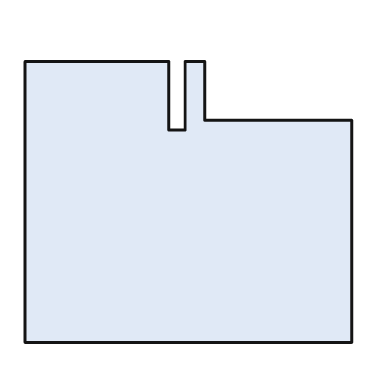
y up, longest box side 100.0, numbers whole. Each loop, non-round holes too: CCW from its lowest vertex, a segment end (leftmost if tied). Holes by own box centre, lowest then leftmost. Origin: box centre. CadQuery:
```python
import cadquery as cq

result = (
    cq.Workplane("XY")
    .moveTo(-50.0, -43.0)
    .lineTo(50.0, -43.0)
    .lineTo(50.0, 25.0)
    .lineTo(5.0, 25.0)
    .lineTo(5.0, 43.0)
    .lineTo(-1.0, 43.0)
    .lineTo(-1.0, 22.0)
    .lineTo(-6.0, 22.0)
    .lineTo(-6.0, 43.0)
    .lineTo(-50.0, 43.0)
    .close()
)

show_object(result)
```